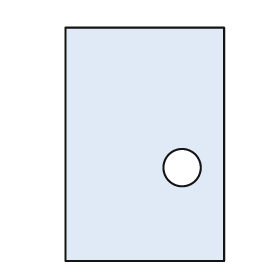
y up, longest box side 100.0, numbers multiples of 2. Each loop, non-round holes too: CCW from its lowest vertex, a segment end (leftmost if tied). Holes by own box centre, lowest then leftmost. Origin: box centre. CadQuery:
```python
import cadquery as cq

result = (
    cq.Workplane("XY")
    .moveTo(-34.0, -50.0)
    .lineTo(34.0, -50.0)
    .lineTo(34.0, 50.0)
    .lineTo(-34.0, 50.0)
    .close()
    .moveTo(16.0, -10.0)
    .circle(8.0)
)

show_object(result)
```